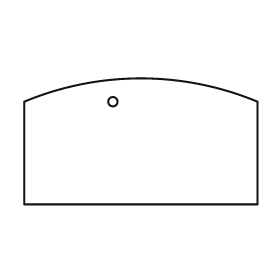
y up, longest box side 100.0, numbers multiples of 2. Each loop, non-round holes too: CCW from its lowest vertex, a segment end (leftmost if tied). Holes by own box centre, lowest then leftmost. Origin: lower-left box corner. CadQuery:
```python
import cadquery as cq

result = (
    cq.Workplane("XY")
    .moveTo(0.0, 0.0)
    .lineTo(100.0, 0.0)
    .lineTo(100.0, 44.0)
    .threePointArc((50.0, 54.0), (0.0, 44.0))
    .close()
    .moveTo(38.0, 44.0)
    .circle(2.0)
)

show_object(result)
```